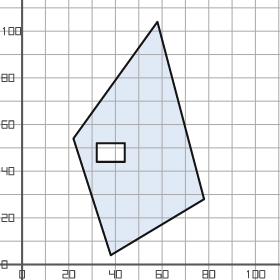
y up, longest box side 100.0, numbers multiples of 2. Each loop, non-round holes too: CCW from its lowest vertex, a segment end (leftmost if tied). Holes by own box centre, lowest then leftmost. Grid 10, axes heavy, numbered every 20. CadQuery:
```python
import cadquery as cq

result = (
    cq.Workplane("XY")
    .moveTo(38.0, 4.0)
    .lineTo(78.0, 28.0)
    .lineTo(58.0, 104.0)
    .lineTo(22.0, 54.0)
    .close()
    .moveTo(32.0, 44.0)
    .lineTo(44.0, 44.0)
    .lineTo(44.0, 52.0)
    .lineTo(32.0, 52.0)
    .close()
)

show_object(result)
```